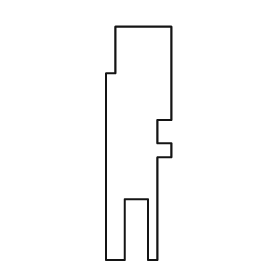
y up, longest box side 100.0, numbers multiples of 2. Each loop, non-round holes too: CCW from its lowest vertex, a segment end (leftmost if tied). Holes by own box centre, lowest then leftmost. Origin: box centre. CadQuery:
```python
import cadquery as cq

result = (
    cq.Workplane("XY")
    .moveTo(-14.0, -50.0)
    .lineTo(-6.0, -50.0)
    .lineTo(-6.0, -24.0)
    .lineTo(4.0, -24.0)
    .lineTo(4.0, -50.0)
    .lineTo(8.0, -50.0)
    .lineTo(8.0, -6.0)
    .lineTo(14.0, -6.0)
    .lineTo(14.0, 0.0)
    .lineTo(8.0, 0.0)
    .lineTo(8.0, 10.0)
    .lineTo(14.0, 10.0)
    .lineTo(14.0, 50.0)
    .lineTo(-10.0, 50.0)
    .lineTo(-10.0, 30.0)
    .lineTo(-14.0, 30.0)
    .close()
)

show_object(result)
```